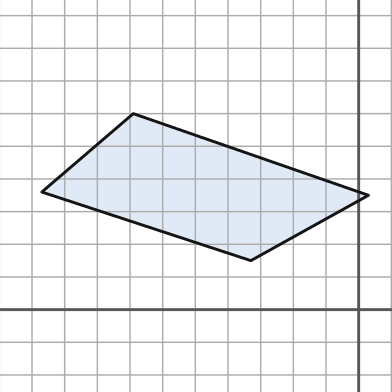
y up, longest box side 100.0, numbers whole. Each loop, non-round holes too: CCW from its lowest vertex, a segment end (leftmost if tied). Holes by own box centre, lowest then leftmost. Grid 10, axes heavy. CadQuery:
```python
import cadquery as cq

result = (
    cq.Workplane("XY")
    .moveTo(-33.0, 15.0)
    .lineTo(3.0, 35.0)
    .lineTo(-69.0, 60.0)
    .lineTo(-97.0, 36.0)
    .close()
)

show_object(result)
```